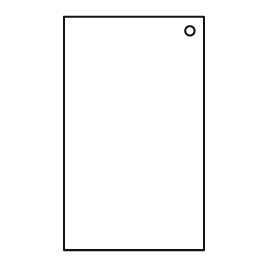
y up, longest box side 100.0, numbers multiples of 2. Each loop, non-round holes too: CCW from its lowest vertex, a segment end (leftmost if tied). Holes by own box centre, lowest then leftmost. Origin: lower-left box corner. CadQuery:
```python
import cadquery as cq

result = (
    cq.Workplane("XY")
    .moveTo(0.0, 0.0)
    .lineTo(60.0, 0.0)
    .lineTo(60.0, 100.0)
    .lineTo(0.0, 100.0)
    .close()
    .moveTo(54.0, 94.0)
    .circle(2.0)
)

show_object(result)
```